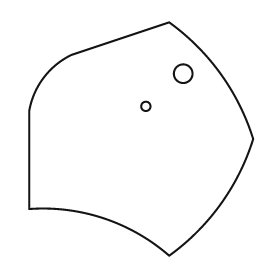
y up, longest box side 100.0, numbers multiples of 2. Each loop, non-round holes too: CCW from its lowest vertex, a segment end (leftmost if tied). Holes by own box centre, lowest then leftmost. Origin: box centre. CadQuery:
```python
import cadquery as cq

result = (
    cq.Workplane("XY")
    .moveTo(12.0, -50.0)
    .threePointArc((34.0, -28.0), (48.0, 0.0))
    .threePointArc((34.0, 28.0), (12.0, 50.0))
    .lineTo(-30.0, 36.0)
    .threePointArc((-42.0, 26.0), (-48.0, 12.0))
    .lineTo(-48.0, -30.0)
    .threePointArc((-16.0, -34.0), (12.0, -50.0))
    .close()
    .moveTo(2.0, 14.0)
    .circle(2.0)
    .moveTo(18.0, 28.0)
    .circle(4.0)
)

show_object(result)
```